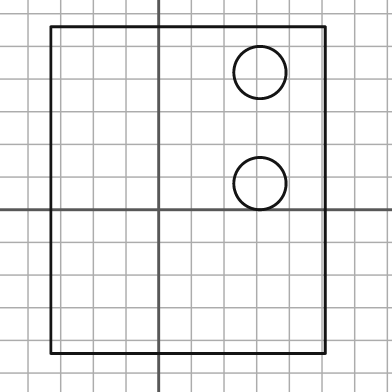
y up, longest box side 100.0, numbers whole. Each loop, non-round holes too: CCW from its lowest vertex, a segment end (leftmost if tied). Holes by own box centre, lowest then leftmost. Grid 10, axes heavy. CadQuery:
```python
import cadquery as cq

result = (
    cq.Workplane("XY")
    .moveTo(-33.0, -44.0)
    .lineTo(51.0, -44.0)
    .lineTo(51.0, 56.0)
    .lineTo(-33.0, 56.0)
    .close()
    .moveTo(31.0, 8.0)
    .circle(8.0)
    .moveTo(31.0, 42.0)
    .circle(8.0)
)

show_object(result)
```